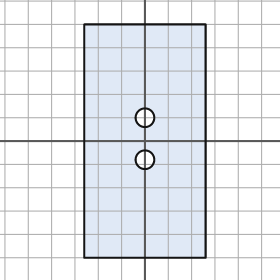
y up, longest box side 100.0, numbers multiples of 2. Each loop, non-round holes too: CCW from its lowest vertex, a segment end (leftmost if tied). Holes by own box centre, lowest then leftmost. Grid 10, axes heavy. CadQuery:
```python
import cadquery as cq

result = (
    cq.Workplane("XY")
    .moveTo(-26.0, -50.0)
    .lineTo(26.0, -50.0)
    .lineTo(26.0, 50.0)
    .lineTo(-26.0, 50.0)
    .close()
    .moveTo(0.0, -8.0)
    .circle(4.0)
    .moveTo(0.0, 10.0)
    .circle(4.0)
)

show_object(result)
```